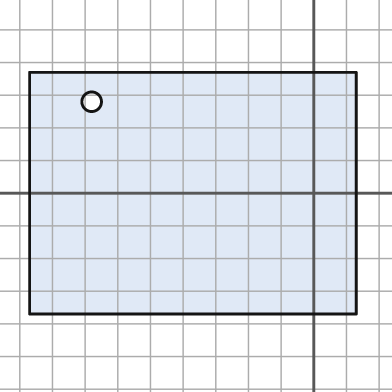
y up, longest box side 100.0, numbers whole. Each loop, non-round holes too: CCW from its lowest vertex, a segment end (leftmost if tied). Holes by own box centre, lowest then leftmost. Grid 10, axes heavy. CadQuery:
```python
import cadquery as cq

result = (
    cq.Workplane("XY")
    .moveTo(-87.0, -37.0)
    .lineTo(13.0, -37.0)
    .lineTo(13.0, 37.0)
    .lineTo(-87.0, 37.0)
    .close()
    .moveTo(-68.0, 28.0)
    .circle(3.0)
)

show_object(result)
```